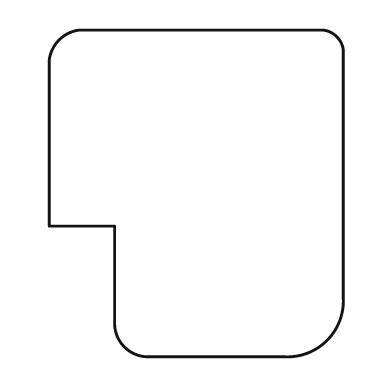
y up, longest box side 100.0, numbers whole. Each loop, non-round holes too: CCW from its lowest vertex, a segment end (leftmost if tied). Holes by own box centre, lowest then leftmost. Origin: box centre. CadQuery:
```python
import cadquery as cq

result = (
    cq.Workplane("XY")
    .moveTo(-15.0, -50.0)
    .lineTo(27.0, -50.0)
    .threePointArc((40.0, -45.0), (45.0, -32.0))
    .lineTo(45.0, 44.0)
    .threePointArc((43.0, 48.0), (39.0, 50.0))
    .lineTo(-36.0, 50.0)
    .threePointArc((-42.0, 47.0), (-45.0, 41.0))
    .lineTo(-45.0, -10.0)
    .lineTo(-25.0, -10.0)
    .lineTo(-25.0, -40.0)
    .threePointArc((-22.0, -47.0), (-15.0, -50.0))
    .close()
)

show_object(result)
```